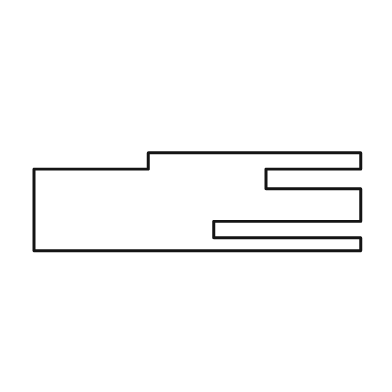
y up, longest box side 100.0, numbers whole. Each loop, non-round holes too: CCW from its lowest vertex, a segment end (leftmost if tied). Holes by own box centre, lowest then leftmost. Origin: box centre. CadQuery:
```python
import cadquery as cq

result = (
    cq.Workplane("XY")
    .moveTo(-50.0, -15.0)
    .lineTo(50.0, -15.0)
    .lineTo(50.0, -11.0)
    .lineTo(5.0, -11.0)
    .lineTo(5.0, -6.0)
    .lineTo(50.0, -6.0)
    .lineTo(50.0, 4.0)
    .lineTo(21.0, 4.0)
    .lineTo(21.0, 10.0)
    .lineTo(50.0, 10.0)
    .lineTo(50.0, 15.0)
    .lineTo(-15.0, 15.0)
    .lineTo(-15.0, 10.0)
    .lineTo(-50.0, 10.0)
    .close()
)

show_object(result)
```